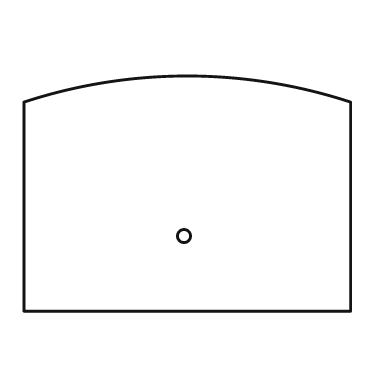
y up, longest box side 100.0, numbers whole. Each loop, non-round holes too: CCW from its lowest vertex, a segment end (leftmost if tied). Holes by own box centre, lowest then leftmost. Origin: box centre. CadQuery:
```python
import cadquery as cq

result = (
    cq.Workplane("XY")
    .moveTo(-50.0, -36.0)
    .lineTo(50.0, -36.0)
    .lineTo(50.0, 28.0)
    .threePointArc((0.0, 36.0), (-50.0, 28.0))
    .close()
    .moveTo(-1.0, -13.0)
    .circle(2.0)
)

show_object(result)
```